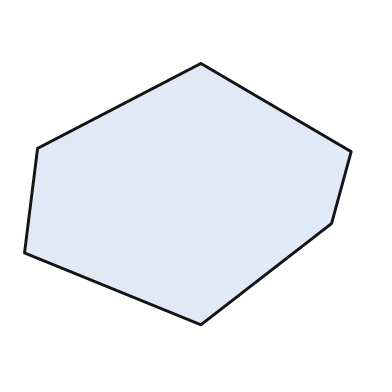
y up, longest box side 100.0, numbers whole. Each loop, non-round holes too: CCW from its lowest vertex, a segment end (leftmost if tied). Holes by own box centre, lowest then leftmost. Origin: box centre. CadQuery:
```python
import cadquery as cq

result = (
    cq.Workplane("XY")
    .moveTo(4.0, -40.0)
    .lineTo(44.0, -9.0)
    .lineTo(50.0, 13.0)
    .lineTo(4.0, 40.0)
    .lineTo(-46.0, 14.0)
    .lineTo(-50.0, -18.0)
    .close()
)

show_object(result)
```